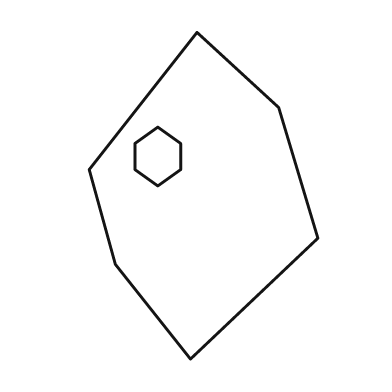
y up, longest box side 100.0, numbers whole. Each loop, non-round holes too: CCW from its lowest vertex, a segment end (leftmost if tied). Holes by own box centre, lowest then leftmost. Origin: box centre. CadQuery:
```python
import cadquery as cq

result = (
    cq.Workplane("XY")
    .moveTo(-4.0, -50.0)
    .lineTo(35.0, -13.0)
    .lineTo(23.0, 27.0)
    .lineTo(-2.0, 50.0)
    .lineTo(-35.0, 8.0)
    .lineTo(-27.0, -21.0)
    .close()
    .moveTo(-14.0, 3.0)
    .lineTo(-7.0, 8.0)
    .lineTo(-7.0, 16.0)
    .lineTo(-14.0, 21.0)
    .lineTo(-21.0, 16.0)
    .lineTo(-21.0, 8.0)
    .close()
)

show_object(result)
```